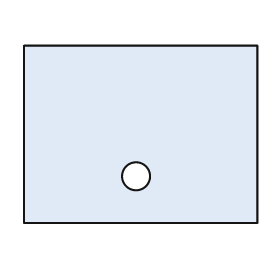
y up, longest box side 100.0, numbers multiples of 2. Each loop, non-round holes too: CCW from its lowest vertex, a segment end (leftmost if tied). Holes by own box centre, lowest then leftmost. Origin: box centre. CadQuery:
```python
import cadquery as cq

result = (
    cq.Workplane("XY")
    .moveTo(-50.0, -38.0)
    .lineTo(50.0, -38.0)
    .lineTo(50.0, 38.0)
    .lineTo(-50.0, 38.0)
    .close()
    .moveTo(-2.0, -18.0)
    .circle(6.0)
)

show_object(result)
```